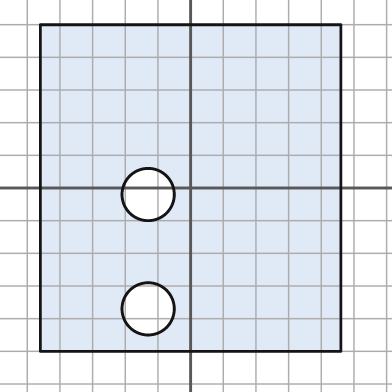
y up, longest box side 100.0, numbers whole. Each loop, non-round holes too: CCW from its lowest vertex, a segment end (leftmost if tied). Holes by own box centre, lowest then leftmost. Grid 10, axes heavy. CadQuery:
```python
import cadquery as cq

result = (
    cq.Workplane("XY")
    .moveTo(-46.0, -50.0)
    .lineTo(46.0, -50.0)
    .lineTo(46.0, 50.0)
    .lineTo(-46.0, 50.0)
    .close()
    .moveTo(-13.0, -37.0)
    .circle(8.0)
    .moveTo(-13.0, -2.0)
    .circle(8.0)
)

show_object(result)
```